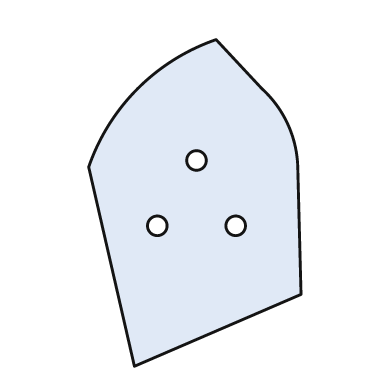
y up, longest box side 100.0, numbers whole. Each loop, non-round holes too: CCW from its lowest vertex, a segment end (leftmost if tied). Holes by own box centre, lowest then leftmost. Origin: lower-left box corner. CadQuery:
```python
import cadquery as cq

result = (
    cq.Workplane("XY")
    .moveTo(14.0, 0.0)
    .lineTo(65.0, 22.0)
    .lineTo(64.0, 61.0)
    .threePointArc((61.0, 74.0), (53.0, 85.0))
    .lineTo(39.0, 100.0)
    .threePointArc((15.0, 85.0), (0.0, 61.0))
    .close()
    .moveTo(21.0, 43.0)
    .circle(3.0)
    .moveTo(45.0, 43.0)
    .circle(3.0)
    .moveTo(33.0, 63.0)
    .circle(3.0)
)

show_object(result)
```